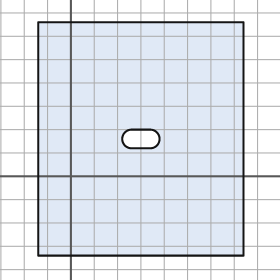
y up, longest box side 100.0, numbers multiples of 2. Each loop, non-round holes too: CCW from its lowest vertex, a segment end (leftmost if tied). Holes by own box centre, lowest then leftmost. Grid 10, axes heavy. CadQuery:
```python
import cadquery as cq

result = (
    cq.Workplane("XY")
    .moveTo(-14.0, -34.0)
    .lineTo(74.0, -34.0)
    .lineTo(74.0, 66.0)
    .lineTo(-14.0, 66.0)
    .close()
    .moveTo(26.0, 12.0)
    .lineTo(34.0, 12.0)
    .threePointArc((38.0, 16.0), (34.0, 20.0))
    .lineTo(26.0, 20.0)
    .threePointArc((22.0, 16.0), (26.0, 12.0))
    .close()
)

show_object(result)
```